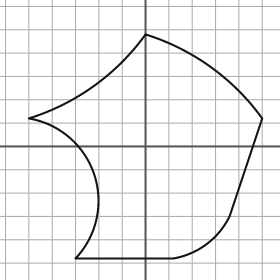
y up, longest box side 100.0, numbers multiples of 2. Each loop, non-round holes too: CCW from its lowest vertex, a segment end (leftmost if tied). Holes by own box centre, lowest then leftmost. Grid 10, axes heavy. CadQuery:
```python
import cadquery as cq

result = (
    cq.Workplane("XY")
    .moveTo(-30.0, -48.0)
    .lineTo(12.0, -48.0)
    .threePointArc((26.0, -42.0), (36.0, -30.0))
    .lineTo(50.0, 12.0)
    .threePointArc((28.0, 34.0), (0.0, 48.0))
    .threePointArc((-22.0, 26.0), (-50.0, 12.0))
    .threePointArc((-22.0, -12.0), (-30.0, -48.0))
    .close()
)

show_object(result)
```